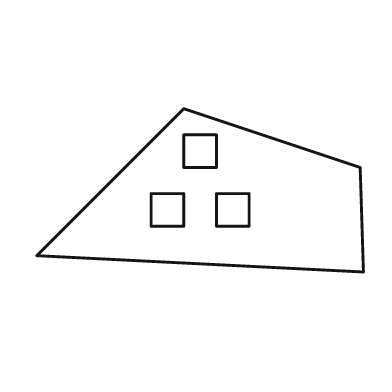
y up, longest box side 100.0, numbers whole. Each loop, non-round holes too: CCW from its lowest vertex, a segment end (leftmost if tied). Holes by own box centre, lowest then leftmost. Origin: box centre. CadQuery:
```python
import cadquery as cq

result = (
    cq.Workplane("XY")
    .moveTo(50.0, -25.0)
    .lineTo(49.0, 7.0)
    .lineTo(-5.0, 25.0)
    .lineTo(-50.0, -20.0)
    .close()
    .moveTo(-15.0, -11.0)
    .lineTo(-5.0, -11.0)
    .lineTo(-5.0, -1.0)
    .lineTo(-15.0, -1.0)
    .close()
    .moveTo(5.0, -11.0)
    .lineTo(15.0, -11.0)
    .lineTo(15.0, -1.0)
    .lineTo(5.0, -1.0)
    .close()
    .moveTo(-5.0, 7.0)
    .lineTo(5.0, 7.0)
    .lineTo(5.0, 17.0)
    .lineTo(-5.0, 17.0)
    .close()
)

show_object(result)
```